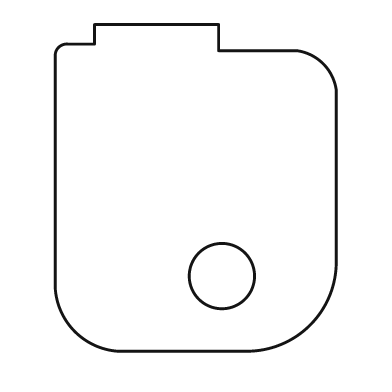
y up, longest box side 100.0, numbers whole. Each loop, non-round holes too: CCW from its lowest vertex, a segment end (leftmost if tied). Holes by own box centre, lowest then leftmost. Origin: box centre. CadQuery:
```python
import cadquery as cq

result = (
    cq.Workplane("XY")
    .moveTo(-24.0, -50.0)
    .lineTo(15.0, -50.0)
    .threePointArc((35.0, -42.0), (43.0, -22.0))
    .lineTo(43.0, 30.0)
    .threePointArc((39.0, 38.0), (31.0, 42.0))
    .lineTo(7.0, 42.0)
    .lineTo(7.0, 50.0)
    .lineTo(-31.0, 50.0)
    .lineTo(-31.0, 44.0)
    .lineTo(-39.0, 44.0)
    .threePointArc((-42.0, 43.0), (-43.0, 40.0))
    .lineTo(-43.0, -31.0)
    .threePointArc((-37.0, -44.0), (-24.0, -50.0))
    .close()
    .moveTo(8.0, -27.0)
    .circle(10.0)
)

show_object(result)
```